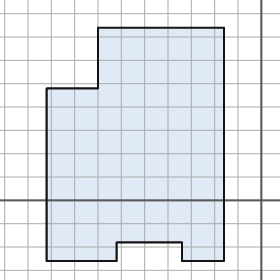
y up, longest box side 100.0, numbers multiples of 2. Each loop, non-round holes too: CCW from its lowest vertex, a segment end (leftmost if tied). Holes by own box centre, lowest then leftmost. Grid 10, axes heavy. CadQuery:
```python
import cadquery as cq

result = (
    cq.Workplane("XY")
    .moveTo(-92.0, -26.0)
    .lineTo(-62.0, -26.0)
    .lineTo(-62.0, -18.0)
    .lineTo(-34.0, -18.0)
    .lineTo(-34.0, -26.0)
    .lineTo(-16.0, -26.0)
    .lineTo(-16.0, 74.0)
    .lineTo(-70.0, 74.0)
    .lineTo(-70.0, 48.0)
    .lineTo(-92.0, 48.0)
    .close()
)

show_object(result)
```